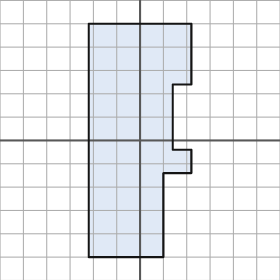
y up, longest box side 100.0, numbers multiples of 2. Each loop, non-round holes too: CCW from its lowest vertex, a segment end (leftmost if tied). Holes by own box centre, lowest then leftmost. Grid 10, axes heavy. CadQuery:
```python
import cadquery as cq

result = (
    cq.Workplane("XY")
    .moveTo(-22.0, -50.0)
    .lineTo(10.0, -50.0)
    .lineTo(10.0, -14.0)
    .lineTo(22.0, -14.0)
    .lineTo(22.0, -4.0)
    .lineTo(14.0, -4.0)
    .lineTo(14.0, 24.0)
    .lineTo(22.0, 24.0)
    .lineTo(22.0, 50.0)
    .lineTo(-22.0, 50.0)
    .close()
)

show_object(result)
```